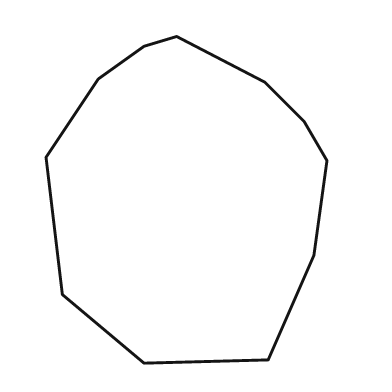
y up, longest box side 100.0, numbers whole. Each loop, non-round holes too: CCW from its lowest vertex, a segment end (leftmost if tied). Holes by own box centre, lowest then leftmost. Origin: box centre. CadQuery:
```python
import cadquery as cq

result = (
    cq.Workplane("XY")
    .moveTo(-13.0, -50.0)
    .lineTo(25.0, -49.0)
    .lineTo(39.0, -17.0)
    .lineTo(43.0, 12.0)
    .lineTo(36.0, 24.0)
    .lineTo(24.0, 36.0)
    .lineTo(-3.0, 50.0)
    .lineTo(-13.0, 47.0)
    .lineTo(-27.0, 37.0)
    .lineTo(-43.0, 13.0)
    .lineTo(-38.0, -29.0)
    .close()
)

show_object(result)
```